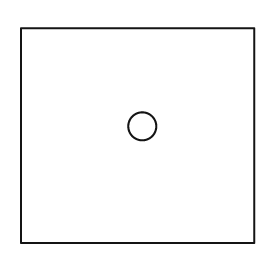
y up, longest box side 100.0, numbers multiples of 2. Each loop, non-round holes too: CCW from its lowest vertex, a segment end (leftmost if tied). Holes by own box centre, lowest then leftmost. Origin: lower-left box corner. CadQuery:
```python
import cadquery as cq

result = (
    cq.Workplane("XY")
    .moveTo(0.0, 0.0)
    .lineTo(100.0, 0.0)
    .lineTo(100.0, 92.0)
    .lineTo(0.0, 92.0)
    .close()
    .moveTo(52.0, 50.0)
    .circle(6.0)
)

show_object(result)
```